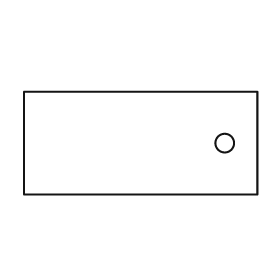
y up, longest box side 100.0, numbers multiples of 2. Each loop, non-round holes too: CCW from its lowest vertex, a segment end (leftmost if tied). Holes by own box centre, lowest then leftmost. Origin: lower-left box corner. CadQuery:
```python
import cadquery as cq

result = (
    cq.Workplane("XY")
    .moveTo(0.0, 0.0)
    .lineTo(100.0, 0.0)
    .lineTo(100.0, 44.0)
    .lineTo(0.0, 44.0)
    .close()
    .moveTo(86.0, 22.0)
    .circle(4.0)
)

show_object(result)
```